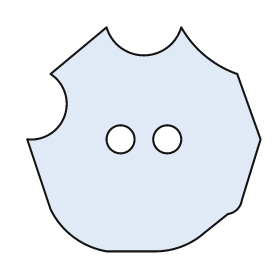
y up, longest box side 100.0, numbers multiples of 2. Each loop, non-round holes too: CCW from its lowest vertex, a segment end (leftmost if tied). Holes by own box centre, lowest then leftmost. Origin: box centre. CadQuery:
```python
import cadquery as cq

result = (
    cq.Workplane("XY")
    .moveTo(-16.0, -48.0)
    .lineTo(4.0, -48.0)
    .threePointArc((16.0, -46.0), (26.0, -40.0))
    .lineTo(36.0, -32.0)
    .threePointArc((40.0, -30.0), (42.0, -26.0))
    .lineTo(50.0, 0.0)
    .lineTo(40.0, 28.0)
    .threePointArc((26.0, 36.0), (16.0, 48.0))
    .threePointArc((0.0, 36.0), (-16.0, 48.0))
    .lineTo(-40.0, 28.0)
    .threePointArc((-34.0, 10.0), (-50.0, 0.0))
    .lineTo(-40.0, -30.0)
    .threePointArc((-30.0, -42.0), (-16.0, -48.0))
    .close()
    .moveTo(-10.0, 0.0)
    .circle(6.0)
    .moveTo(10.0, 0.0)
    .circle(6.0)
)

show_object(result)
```